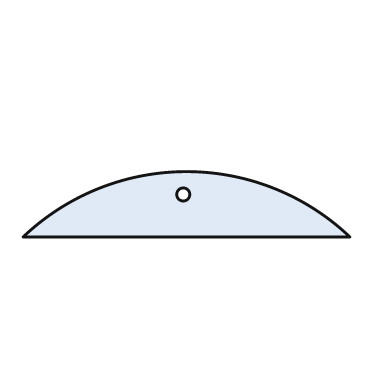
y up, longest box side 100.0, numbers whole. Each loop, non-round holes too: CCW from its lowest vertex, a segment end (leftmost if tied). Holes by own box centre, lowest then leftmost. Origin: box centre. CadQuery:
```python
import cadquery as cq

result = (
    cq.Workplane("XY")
    .moveTo(-50.0, -10.0)
    .lineTo(50.0, -10.0)
    .threePointArc((0.0, 10.0), (-50.0, -10.0))
    .close()
    .moveTo(-1.0, 3.0)
    .circle(2.0)
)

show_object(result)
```